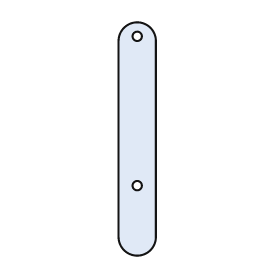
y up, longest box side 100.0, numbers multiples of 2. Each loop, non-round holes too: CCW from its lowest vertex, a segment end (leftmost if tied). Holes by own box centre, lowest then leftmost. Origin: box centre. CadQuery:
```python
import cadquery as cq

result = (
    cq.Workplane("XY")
    .moveTo(-8.0, -42.0)
    .threePointArc((0.0, -50.0), (8.0, -42.0))
    .lineTo(8.0, 42.0)
    .threePointArc((0.0, 50.0), (-8.0, 42.0))
    .close()
    .moveTo(0.0, -20.0)
    .circle(2.0)
    .moveTo(0.0, 44.0)
    .circle(2.0)
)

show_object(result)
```